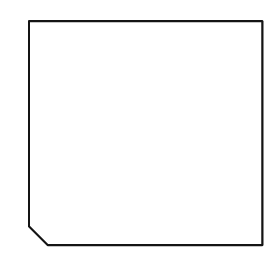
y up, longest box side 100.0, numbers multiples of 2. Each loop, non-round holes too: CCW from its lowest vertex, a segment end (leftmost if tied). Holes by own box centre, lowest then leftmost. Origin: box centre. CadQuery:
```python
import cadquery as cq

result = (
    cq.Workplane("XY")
    .moveTo(-42.0, -48.0)
    .lineTo(50.0, -48.0)
    .lineTo(50.0, 48.0)
    .lineTo(-50.0, 48.0)
    .lineTo(-50.0, -40.0)
    .close()
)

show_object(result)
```